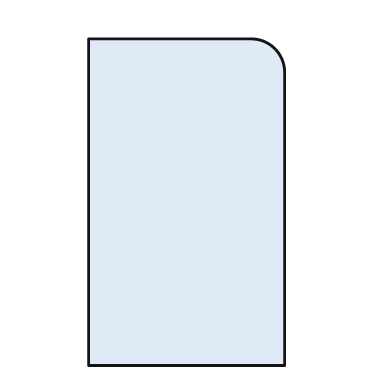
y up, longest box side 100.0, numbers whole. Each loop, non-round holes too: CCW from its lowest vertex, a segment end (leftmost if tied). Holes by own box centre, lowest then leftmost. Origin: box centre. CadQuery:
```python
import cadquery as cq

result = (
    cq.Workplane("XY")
    .moveTo(-30.0, -50.0)
    .lineTo(30.0, -50.0)
    .lineTo(30.0, 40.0)
    .threePointArc((27.0, 47.0), (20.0, 50.0))
    .lineTo(-30.0, 50.0)
    .close()
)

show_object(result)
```